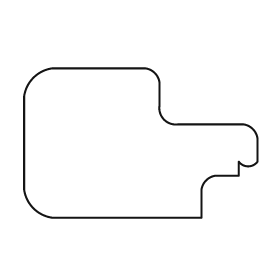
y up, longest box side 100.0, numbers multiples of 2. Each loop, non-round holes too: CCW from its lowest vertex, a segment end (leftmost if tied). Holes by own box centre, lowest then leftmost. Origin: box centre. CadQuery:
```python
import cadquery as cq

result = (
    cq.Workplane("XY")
    .moveTo(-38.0, -32.0)
    .lineTo(26.0, -32.0)
    .lineTo(26.0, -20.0)
    .threePointArc((28.0, -16.0), (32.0, -14.0))
    .lineTo(42.0, -14.0)
    .lineTo(42.0, -8.0)
    .threePointArc((46.0, -10.0), (50.0, -8.0))
    .lineTo(50.0, 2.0)
    .threePointArc((48.0, 6.0), (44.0, 8.0))
    .lineTo(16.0, 8.0)
    .threePointArc((10.0, 10.0), (8.0, 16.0))
    .lineTo(8.0, 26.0)
    .threePointArc((6.0, 30.0), (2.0, 32.0))
    .lineTo(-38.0, 32.0)
    .threePointArc((-46.0, 28.0), (-50.0, 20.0))
    .lineTo(-50.0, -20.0)
    .threePointArc((-46.0, -28.0), (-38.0, -32.0))
    .close()
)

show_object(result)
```